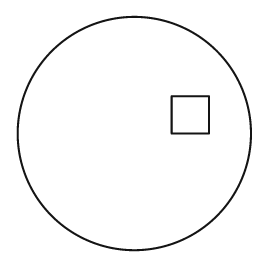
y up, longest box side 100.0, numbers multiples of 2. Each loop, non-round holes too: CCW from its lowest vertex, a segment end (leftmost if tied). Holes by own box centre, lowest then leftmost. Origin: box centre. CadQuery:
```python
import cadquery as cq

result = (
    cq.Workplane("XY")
    .moveTo(0.0, 0.0)
    .circle(50.0)
    .moveTo(16.0, 0.0)
    .lineTo(32.0, 0.0)
    .lineTo(32.0, 16.0)
    .lineTo(16.0, 16.0)
    .close()
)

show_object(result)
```